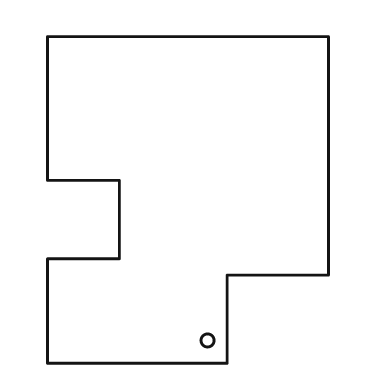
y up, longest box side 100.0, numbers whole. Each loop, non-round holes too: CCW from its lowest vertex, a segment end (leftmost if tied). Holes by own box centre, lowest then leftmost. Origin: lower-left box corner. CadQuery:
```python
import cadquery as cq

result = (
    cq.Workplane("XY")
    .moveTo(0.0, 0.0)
    .lineTo(55.0, 0.0)
    .lineTo(55.0, 27.0)
    .lineTo(86.0, 27.0)
    .lineTo(86.0, 100.0)
    .lineTo(0.0, 100.0)
    .lineTo(0.0, 56.0)
    .lineTo(22.0, 56.0)
    .lineTo(22.0, 32.0)
    .lineTo(0.0, 32.0)
    .close()
    .moveTo(49.0, 7.0)
    .circle(2.0)
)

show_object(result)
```